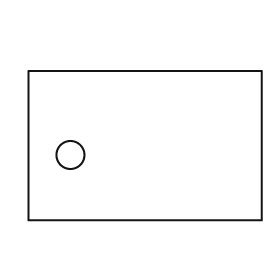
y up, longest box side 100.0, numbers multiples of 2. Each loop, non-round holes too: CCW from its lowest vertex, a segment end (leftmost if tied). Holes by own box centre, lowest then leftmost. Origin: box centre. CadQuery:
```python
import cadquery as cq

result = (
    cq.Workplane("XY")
    .moveTo(-50.0, -32.0)
    .lineTo(50.0, -32.0)
    .lineTo(50.0, 32.0)
    .lineTo(-50.0, 32.0)
    .close()
    .moveTo(-32.0, -4.0)
    .circle(6.0)
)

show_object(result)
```